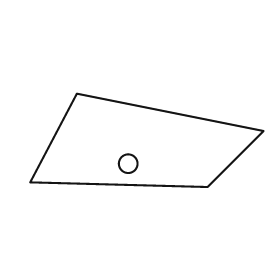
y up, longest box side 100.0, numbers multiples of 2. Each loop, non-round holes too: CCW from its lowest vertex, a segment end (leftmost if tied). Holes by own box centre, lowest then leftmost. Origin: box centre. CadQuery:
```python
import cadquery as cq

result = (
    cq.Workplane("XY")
    .moveTo(26.0, -20.0)
    .lineTo(50.0, 4.0)
    .lineTo(-30.0, 20.0)
    .lineTo(-50.0, -18.0)
    .close()
    .moveTo(-8.0, -10.0)
    .circle(4.0)
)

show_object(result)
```